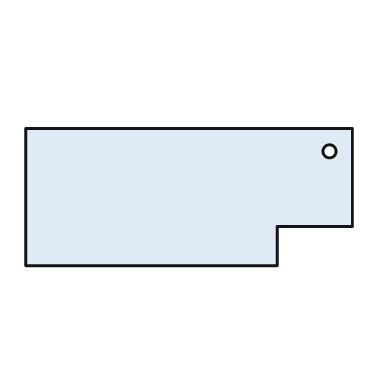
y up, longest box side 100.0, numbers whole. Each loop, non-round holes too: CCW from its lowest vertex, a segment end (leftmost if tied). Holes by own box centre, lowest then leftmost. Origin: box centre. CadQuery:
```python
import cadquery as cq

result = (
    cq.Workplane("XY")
    .moveTo(-50.0, -21.0)
    .lineTo(27.0, -21.0)
    .lineTo(27.0, -9.0)
    .lineTo(50.0, -9.0)
    .lineTo(50.0, 21.0)
    .lineTo(-50.0, 21.0)
    .close()
    .moveTo(43.0, 14.0)
    .circle(2.0)
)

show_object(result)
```